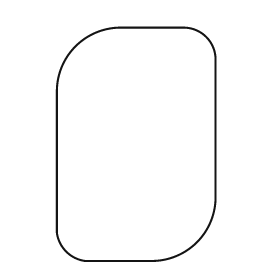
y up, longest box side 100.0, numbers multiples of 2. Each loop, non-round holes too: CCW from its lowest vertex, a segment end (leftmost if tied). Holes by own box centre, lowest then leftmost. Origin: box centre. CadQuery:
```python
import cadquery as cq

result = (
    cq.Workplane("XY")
    .moveTo(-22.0, -50.0)
    .lineTo(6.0, -50.0)
    .threePointArc((26.0, -42.0), (34.0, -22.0))
    .lineTo(34.0, 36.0)
    .threePointArc((30.0, 46.0), (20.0, 50.0))
    .lineTo(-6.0, 50.0)
    .threePointArc((-26.0, 42.0), (-34.0, 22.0))
    .lineTo(-34.0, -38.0)
    .threePointArc((-30.0, -46.0), (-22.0, -50.0))
    .close()
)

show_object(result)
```